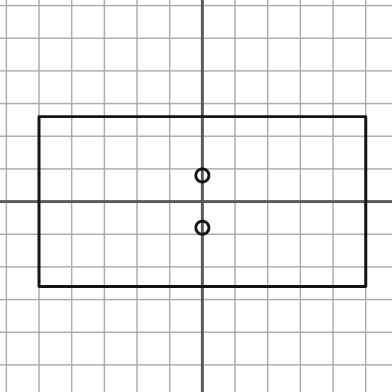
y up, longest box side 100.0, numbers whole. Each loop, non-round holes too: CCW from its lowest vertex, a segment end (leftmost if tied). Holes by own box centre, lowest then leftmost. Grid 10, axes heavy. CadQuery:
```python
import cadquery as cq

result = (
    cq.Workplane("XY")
    .moveTo(-50.0, -26.0)
    .lineTo(50.0, -26.0)
    .lineTo(50.0, 26.0)
    .lineTo(-50.0, 26.0)
    .close()
    .moveTo(0.0, -8.0)
    .circle(2.0)
    .moveTo(0.0, 8.0)
    .circle(2.0)
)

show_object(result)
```